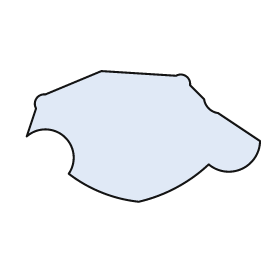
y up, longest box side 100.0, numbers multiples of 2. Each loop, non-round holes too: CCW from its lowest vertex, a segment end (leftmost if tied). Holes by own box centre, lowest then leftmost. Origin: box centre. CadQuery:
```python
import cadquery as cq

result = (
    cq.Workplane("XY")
    .moveTo(-2.0, -28.0)
    .threePointArc((14.0, -22.0), (28.0, -12.0))
    .threePointArc((42.0, -14.0), (50.0, -2.0))
    .lineTo(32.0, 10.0)
    .threePointArc((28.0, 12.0), (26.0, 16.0))
    .lineTo(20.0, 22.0)
    .threePointArc((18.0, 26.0), (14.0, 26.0))
    .lineTo(-18.0, 28.0)
    .lineTo(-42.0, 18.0)
    .threePointArc((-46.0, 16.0), (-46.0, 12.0))
    .lineTo(-50.0, 0.0)
    .threePointArc((-34.0, 0.0), (-32.0, -16.0))
    .threePointArc((-18.0, -24.0), (-2.0, -28.0))
    .close()
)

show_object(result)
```